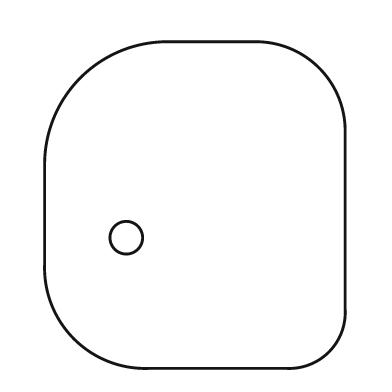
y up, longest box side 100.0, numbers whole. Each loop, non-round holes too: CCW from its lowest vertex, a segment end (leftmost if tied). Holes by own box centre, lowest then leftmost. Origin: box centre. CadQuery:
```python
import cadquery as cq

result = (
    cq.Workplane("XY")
    .moveTo(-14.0, -50.0)
    .lineTo(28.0, -50.0)
    .threePointArc((41.0, -45.0), (46.0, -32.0))
    .lineTo(46.0, 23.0)
    .threePointArc((38.0, 42.0), (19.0, 50.0))
    .lineTo(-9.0, 50.0)
    .threePointArc((-35.0, 39.0), (-46.0, 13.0))
    .lineTo(-46.0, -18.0)
    .threePointArc((-37.0, -41.0), (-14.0, -50.0))
    .close()
    .moveTo(-21.0, -10.0)
    .circle(5.0)
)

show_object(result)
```